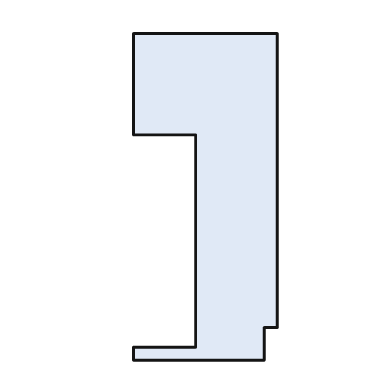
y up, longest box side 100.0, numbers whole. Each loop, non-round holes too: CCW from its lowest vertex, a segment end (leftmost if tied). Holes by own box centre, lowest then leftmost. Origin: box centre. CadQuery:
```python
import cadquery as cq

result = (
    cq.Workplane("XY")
    .moveTo(-22.0, -50.0)
    .lineTo(18.0, -50.0)
    .lineTo(18.0, -40.0)
    .lineTo(22.0, -40.0)
    .lineTo(22.0, 50.0)
    .lineTo(-22.0, 50.0)
    .lineTo(-22.0, 19.0)
    .lineTo(-3.0, 19.0)
    .lineTo(-3.0, -46.0)
    .lineTo(-22.0, -46.0)
    .close()
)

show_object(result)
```